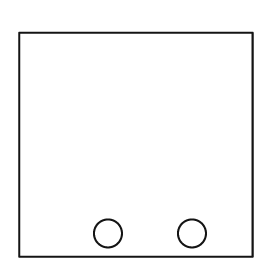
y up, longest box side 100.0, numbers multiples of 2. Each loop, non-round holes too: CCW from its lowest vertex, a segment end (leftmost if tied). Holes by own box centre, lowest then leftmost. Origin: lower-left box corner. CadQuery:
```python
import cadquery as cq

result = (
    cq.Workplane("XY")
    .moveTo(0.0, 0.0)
    .lineTo(100.0, 0.0)
    .lineTo(100.0, 96.0)
    .lineTo(0.0, 96.0)
    .close()
    .moveTo(38.0, 10.0)
    .circle(6.0)
    .moveTo(74.0, 10.0)
    .circle(6.0)
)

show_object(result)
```